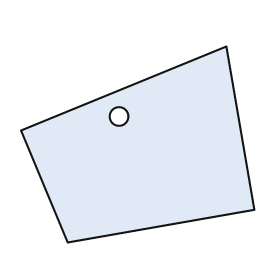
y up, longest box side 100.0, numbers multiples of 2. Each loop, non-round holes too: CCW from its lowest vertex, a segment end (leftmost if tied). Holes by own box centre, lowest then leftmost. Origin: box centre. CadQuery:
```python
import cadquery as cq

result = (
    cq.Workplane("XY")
    .moveTo(-30.0, -42.0)
    .lineTo(50.0, -28.0)
    .lineTo(38.0, 42.0)
    .lineTo(-50.0, 6.0)
    .close()
    .moveTo(-8.0, 12.0)
    .circle(4.0)
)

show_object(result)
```